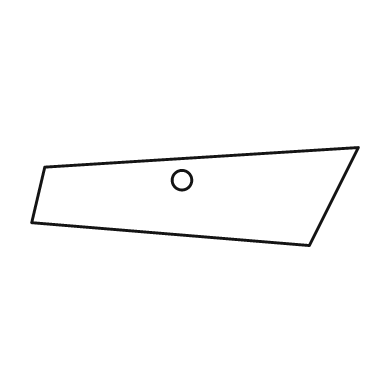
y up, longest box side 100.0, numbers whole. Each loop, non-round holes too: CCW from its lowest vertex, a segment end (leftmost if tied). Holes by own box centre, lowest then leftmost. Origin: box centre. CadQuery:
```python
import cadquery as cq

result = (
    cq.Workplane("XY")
    .moveTo(35.0, -15.0)
    .lineTo(50.0, 15.0)
    .lineTo(-46.0, 9.0)
    .lineTo(-50.0, -8.0)
    .close()
    .moveTo(-4.0, 5.0)
    .circle(3.0)
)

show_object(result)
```